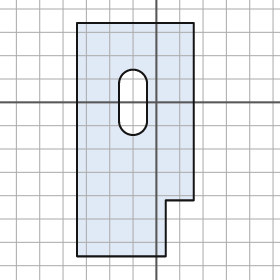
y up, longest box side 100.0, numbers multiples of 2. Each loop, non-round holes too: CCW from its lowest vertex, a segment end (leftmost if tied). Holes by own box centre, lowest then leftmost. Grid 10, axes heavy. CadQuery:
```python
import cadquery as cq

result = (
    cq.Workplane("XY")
    .moveTo(-34.0, -66.0)
    .lineTo(4.0, -66.0)
    .lineTo(4.0, -42.0)
    .lineTo(16.0, -42.0)
    .lineTo(16.0, 34.0)
    .lineTo(-34.0, 34.0)
    .close()
    .moveTo(-16.0, -8.0)
    .threePointArc((-10.0, -14.0), (-4.0, -8.0))
    .lineTo(-4.0, 8.0)
    .threePointArc((-10.0, 14.0), (-16.0, 8.0))
    .close()
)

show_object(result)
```